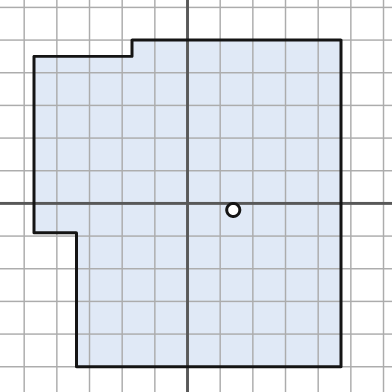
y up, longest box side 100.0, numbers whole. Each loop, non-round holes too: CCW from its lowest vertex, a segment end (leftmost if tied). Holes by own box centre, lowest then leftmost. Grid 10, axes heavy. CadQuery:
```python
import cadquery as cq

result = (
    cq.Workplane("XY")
    .moveTo(-34.0, -50.0)
    .lineTo(47.0, -50.0)
    .lineTo(47.0, 50.0)
    .lineTo(-17.0, 50.0)
    .lineTo(-17.0, 45.0)
    .lineTo(-47.0, 45.0)
    .lineTo(-47.0, -9.0)
    .lineTo(-34.0, -9.0)
    .close()
    .moveTo(14.0, -2.0)
    .circle(2.0)
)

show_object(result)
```